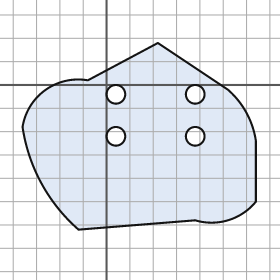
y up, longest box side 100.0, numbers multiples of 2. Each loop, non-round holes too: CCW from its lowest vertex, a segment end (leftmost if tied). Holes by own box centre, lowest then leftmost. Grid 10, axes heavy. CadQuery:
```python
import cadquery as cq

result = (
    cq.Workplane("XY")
    .moveTo(-12.0, -62.0)
    .lineTo(38.0, -58.0)
    .threePointArc((52.0, -58.0), (64.0, -50.0))
    .lineTo(64.0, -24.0)
    .threePointArc((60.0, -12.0), (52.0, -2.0))
    .lineTo(22.0, 18.0)
    .lineTo(-8.0, 2.0)
    .threePointArc((-26.0, -2.0), (-36.0, -18.0))
    .threePointArc((-28.0, -42.0), (-12.0, -62.0))
    .close()
    .moveTo(4.0, -22.0)
    .circle(4.0)
    .moveTo(38.0, -22.0)
    .circle(4.0)
    .moveTo(4.0, -4.0)
    .circle(4.0)
    .moveTo(38.0, -4.0)
    .circle(4.0)
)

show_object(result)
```